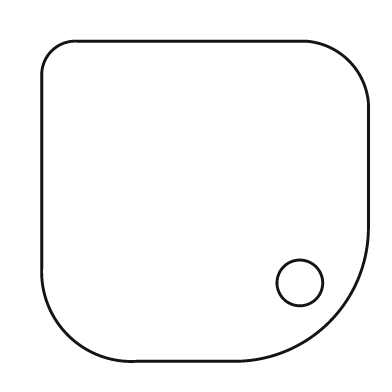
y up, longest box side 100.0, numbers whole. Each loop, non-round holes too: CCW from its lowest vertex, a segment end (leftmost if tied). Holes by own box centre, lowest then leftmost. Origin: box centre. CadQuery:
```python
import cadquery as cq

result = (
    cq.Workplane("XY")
    .moveTo(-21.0, -49.0)
    .lineTo(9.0, -49.0)
    .threePointArc((38.0, -37.0), (50.0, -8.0))
    .lineTo(50.0, 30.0)
    .threePointArc((44.0, 43.0), (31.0, 49.0))
    .lineTo(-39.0, 49.0)
    .threePointArc((-47.0, 46.0), (-50.0, 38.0))
    .lineTo(-50.0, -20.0)
    .threePointArc((-42.0, -41.0), (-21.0, -49.0))
    .close()
    .moveTo(29.0, -25.0)
    .circle(7.0)
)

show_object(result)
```